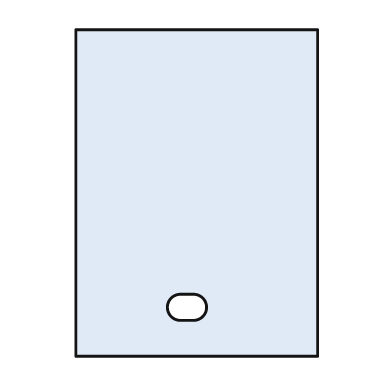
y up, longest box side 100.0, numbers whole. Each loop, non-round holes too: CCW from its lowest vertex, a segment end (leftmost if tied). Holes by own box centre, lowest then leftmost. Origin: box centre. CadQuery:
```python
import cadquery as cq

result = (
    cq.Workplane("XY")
    .moveTo(-37.0, -50.0)
    .lineTo(37.0, -50.0)
    .lineTo(37.0, 50.0)
    .lineTo(-37.0, 50.0)
    .close()
    .moveTo(-5.0, -39.0)
    .lineTo(-1.0, -39.0)
    .threePointArc((3.0, -35.0), (-1.0, -31.0))
    .lineTo(-5.0, -31.0)
    .threePointArc((-9.0, -35.0), (-5.0, -39.0))
    .close()
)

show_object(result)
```